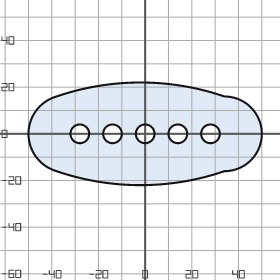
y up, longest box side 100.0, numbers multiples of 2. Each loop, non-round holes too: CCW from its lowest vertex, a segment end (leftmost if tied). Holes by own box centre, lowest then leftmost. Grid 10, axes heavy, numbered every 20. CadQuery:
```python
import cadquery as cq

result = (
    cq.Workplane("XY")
    .moveTo(-38.0, -16.0)
    .threePointArc((-2.0, -22.0), (34.0, -16.0))
    .threePointArc((50.0, 0.0), (34.0, 16.0))
    .threePointArc((-2.0, 22.0), (-38.0, 16.0))
    .threePointArc((-50.0, 0.0), (-38.0, -16.0))
    .close()
    .moveTo(-28.0, 0.0)
    .circle(4.0)
    .moveTo(-14.0, 0.0)
    .circle(4.0)
    .moveTo(0.0, 0.0)
    .circle(4.0)
    .moveTo(14.0, 0.0)
    .circle(4.0)
    .moveTo(28.0, 0.0)
    .circle(4.0)
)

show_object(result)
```